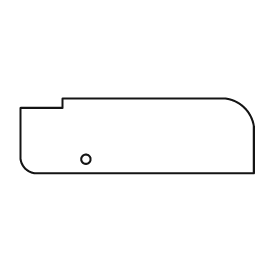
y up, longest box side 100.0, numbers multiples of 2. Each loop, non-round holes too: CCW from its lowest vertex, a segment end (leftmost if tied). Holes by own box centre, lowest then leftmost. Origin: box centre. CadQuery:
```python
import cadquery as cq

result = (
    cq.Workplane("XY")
    .moveTo(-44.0, -16.0)
    .lineTo(50.0, -16.0)
    .lineTo(50.0, 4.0)
    .threePointArc((46.0, 12.0), (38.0, 16.0))
    .lineTo(-32.0, 16.0)
    .lineTo(-32.0, 12.0)
    .lineTo(-50.0, 12.0)
    .lineTo(-50.0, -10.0)
    .threePointArc((-48.0, -14.0), (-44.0, -16.0))
    .close()
    .moveTo(-22.0, -10.0)
    .circle(2.0)
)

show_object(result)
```